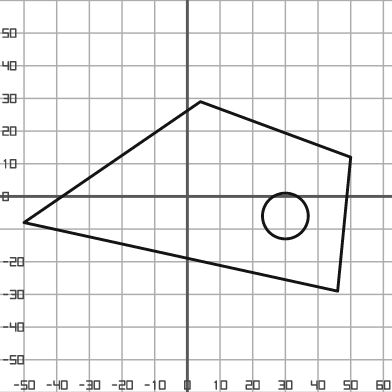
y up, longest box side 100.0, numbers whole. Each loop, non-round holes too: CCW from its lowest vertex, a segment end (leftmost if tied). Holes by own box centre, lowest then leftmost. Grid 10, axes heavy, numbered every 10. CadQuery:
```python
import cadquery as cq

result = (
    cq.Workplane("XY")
    .moveTo(46.0, -29.0)
    .lineTo(50.0, 12.0)
    .lineTo(4.0, 29.0)
    .lineTo(-50.0, -8.0)
    .close()
    .moveTo(30.0, -6.0)
    .circle(7.0)
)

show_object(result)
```